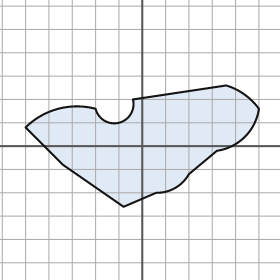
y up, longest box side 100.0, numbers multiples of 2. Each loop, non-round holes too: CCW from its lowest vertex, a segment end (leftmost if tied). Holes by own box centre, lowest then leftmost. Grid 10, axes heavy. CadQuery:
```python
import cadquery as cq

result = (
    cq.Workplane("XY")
    .moveTo(-8.0, -26.0)
    .lineTo(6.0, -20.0)
    .threePointArc((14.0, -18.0), (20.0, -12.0))
    .lineTo(32.0, -2.0)
    .threePointArc((44.0, 4.0), (50.0, 16.0))
    .threePointArc((44.0, 22.0), (36.0, 26.0))
    .lineTo(-4.0, 20.0)
    .threePointArc((-10.0, 10.0), (-20.0, 16.0))
    .threePointArc((-36.0, 16.0), (-50.0, 8.0))
    .lineTo(-34.0, -8.0)
    .close()
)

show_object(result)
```